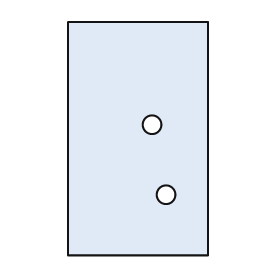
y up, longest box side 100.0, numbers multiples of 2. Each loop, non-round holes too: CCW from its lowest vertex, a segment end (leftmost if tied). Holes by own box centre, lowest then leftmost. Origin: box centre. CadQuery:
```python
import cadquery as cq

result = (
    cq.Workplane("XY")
    .moveTo(-30.0, -50.0)
    .lineTo(30.0, -50.0)
    .lineTo(30.0, 50.0)
    .lineTo(-30.0, 50.0)
    .close()
    .moveTo(12.0, -24.0)
    .circle(4.0)
    .moveTo(6.0, 6.0)
    .circle(4.0)
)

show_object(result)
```